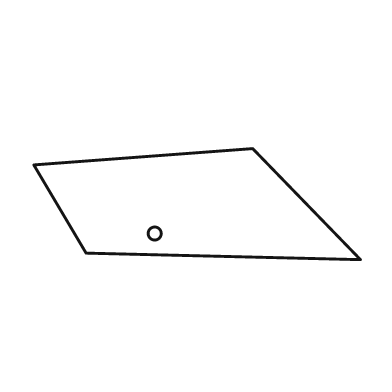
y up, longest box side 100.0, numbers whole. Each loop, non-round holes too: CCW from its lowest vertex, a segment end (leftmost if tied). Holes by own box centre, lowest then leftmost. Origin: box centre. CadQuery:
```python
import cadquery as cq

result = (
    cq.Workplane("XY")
    .moveTo(50.0, -17.0)
    .lineTo(17.0, 17.0)
    .lineTo(-50.0, 12.0)
    .lineTo(-34.0, -15.0)
    .close()
    .moveTo(-13.0, -9.0)
    .circle(2.0)
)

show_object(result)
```